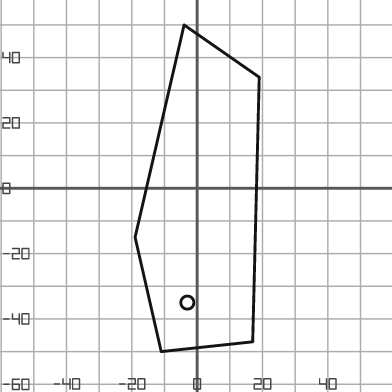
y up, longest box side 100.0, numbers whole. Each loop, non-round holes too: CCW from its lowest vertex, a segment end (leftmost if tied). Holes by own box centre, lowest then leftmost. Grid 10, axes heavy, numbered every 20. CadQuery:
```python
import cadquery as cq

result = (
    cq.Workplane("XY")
    .moveTo(-11.0, -50.0)
    .lineTo(17.0, -47.0)
    .lineTo(19.0, 34.0)
    .lineTo(-4.0, 50.0)
    .lineTo(-19.0, -15.0)
    .close()
    .moveTo(-3.0, -35.0)
    .circle(2.0)
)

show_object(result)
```